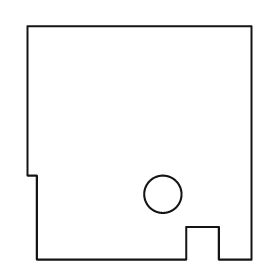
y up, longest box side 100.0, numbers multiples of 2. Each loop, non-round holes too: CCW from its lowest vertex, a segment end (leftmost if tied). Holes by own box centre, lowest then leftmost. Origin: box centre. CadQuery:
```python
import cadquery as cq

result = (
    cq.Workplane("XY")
    .moveTo(-44.0, -50.0)
    .lineTo(20.0, -50.0)
    .lineTo(20.0, -36.0)
    .lineTo(34.0, -36.0)
    .lineTo(34.0, -50.0)
    .lineTo(48.0, -50.0)
    .lineTo(48.0, 50.0)
    .lineTo(-48.0, 50.0)
    .lineTo(-48.0, -14.0)
    .lineTo(-44.0, -14.0)
    .close()
    .moveTo(10.0, -22.0)
    .circle(8.0)
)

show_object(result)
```